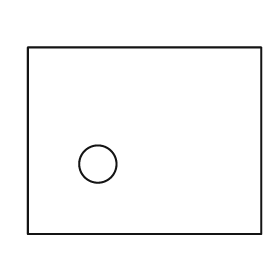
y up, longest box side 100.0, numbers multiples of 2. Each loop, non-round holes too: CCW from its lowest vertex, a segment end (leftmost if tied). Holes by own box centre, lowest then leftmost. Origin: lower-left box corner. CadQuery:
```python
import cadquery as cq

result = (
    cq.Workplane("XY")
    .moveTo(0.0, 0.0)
    .lineTo(100.0, 0.0)
    .lineTo(100.0, 80.0)
    .lineTo(0.0, 80.0)
    .close()
    .moveTo(30.0, 30.0)
    .circle(8.0)
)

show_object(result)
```